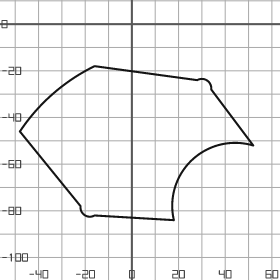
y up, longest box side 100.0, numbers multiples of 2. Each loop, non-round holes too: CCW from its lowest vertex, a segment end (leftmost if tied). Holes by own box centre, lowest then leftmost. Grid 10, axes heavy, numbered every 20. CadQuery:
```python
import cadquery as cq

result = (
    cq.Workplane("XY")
    .moveTo(18.0, -84.0)
    .threePointArc((26.0, -58.0), (52.0, -52.0))
    .lineTo(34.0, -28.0)
    .threePointArc((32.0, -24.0), (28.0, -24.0))
    .lineTo(-16.0, -18.0)
    .threePointArc((-34.0, -30.0), (-48.0, -46.0))
    .lineTo(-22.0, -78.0)
    .threePointArc((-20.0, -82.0), (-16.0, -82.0))
    .close()
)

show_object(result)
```